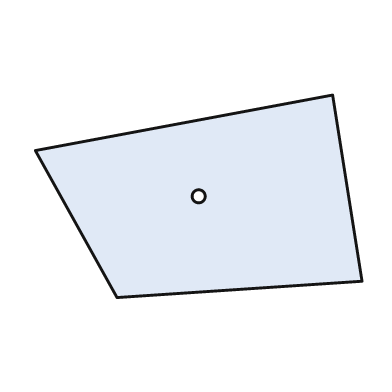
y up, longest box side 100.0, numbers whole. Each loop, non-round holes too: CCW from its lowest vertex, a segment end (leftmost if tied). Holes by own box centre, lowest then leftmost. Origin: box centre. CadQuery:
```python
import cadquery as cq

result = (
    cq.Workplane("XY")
    .moveTo(-25.0, -31.0)
    .lineTo(50.0, -26.0)
    .lineTo(41.0, 31.0)
    .lineTo(-50.0, 14.0)
    .close()
    .moveTo(0.0, 0.0)
    .circle(2.0)
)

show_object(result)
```